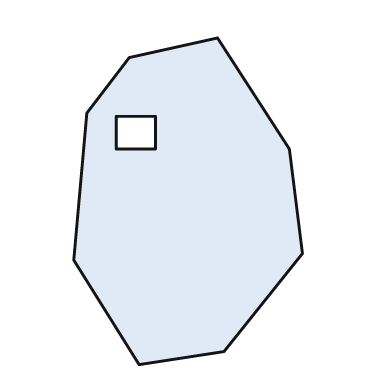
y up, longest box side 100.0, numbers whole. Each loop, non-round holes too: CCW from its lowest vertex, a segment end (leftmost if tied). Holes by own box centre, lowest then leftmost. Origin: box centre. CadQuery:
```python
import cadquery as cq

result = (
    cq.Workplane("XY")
    .moveTo(-15.0, -50.0)
    .lineTo(11.0, -46.0)
    .lineTo(35.0, -16.0)
    .lineTo(31.0, 16.0)
    .lineTo(9.0, 50.0)
    .lineTo(-18.0, 44.0)
    .lineTo(-31.0, 27.0)
    .lineTo(-35.0, -18.0)
    .close()
    .moveTo(-22.0, 16.0)
    .lineTo(-10.0, 16.0)
    .lineTo(-10.0, 26.0)
    .lineTo(-22.0, 26.0)
    .close()
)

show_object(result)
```